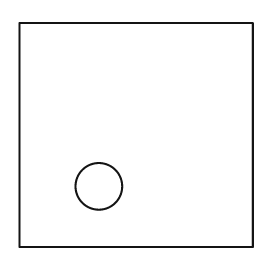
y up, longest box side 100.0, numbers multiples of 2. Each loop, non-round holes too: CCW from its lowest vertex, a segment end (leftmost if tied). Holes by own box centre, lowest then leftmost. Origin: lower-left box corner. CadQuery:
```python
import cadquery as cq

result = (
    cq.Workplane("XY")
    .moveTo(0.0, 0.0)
    .lineTo(100.0, 0.0)
    .lineTo(100.0, 96.0)
    .lineTo(0.0, 96.0)
    .close()
    .moveTo(34.0, 26.0)
    .circle(10.0)
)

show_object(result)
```